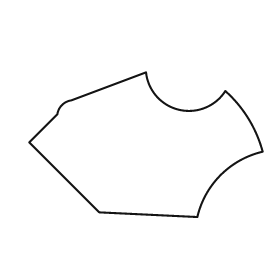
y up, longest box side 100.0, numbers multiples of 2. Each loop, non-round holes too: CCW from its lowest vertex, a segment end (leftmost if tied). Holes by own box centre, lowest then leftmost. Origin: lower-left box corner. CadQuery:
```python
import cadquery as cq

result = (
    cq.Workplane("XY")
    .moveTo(72.0, 0.0)
    .threePointArc((82.0, 18.0), (100.0, 28.0))
    .threePointArc((94.0, 42.0), (84.0, 54.0))
    .threePointArc((64.0, 46.0), (50.0, 62.0))
    .lineTo(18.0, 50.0)
    .threePointArc((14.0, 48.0), (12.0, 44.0))
    .lineTo(0.0, 32.0)
    .lineTo(30.0, 2.0)
    .close()
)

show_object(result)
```